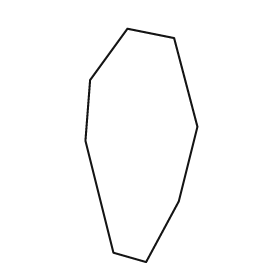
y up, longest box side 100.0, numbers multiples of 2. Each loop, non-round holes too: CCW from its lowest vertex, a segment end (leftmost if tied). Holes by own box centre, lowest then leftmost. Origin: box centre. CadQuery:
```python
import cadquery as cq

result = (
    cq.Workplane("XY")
    .moveTo(2.0, -50.0)
    .lineTo(16.0, -24.0)
    .lineTo(24.0, 8.0)
    .lineTo(14.0, 46.0)
    .lineTo(-6.0, 50.0)
    .lineTo(-22.0, 28.0)
    .lineTo(-24.0, 2.0)
    .lineTo(-12.0, -46.0)
    .close()
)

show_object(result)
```